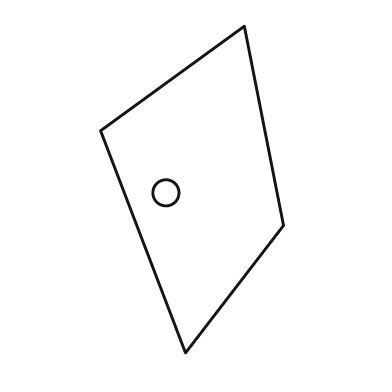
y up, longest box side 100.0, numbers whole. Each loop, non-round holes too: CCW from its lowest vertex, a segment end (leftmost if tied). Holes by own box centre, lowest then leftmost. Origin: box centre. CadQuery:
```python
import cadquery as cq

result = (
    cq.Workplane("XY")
    .moveTo(-2.0, -50.0)
    .lineTo(28.0, -11.0)
    .lineTo(16.0, 50.0)
    .lineTo(-28.0, 18.0)
    .close()
    .moveTo(-8.0, -1.0)
    .circle(4.0)
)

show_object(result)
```